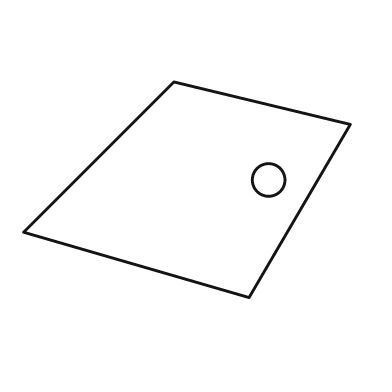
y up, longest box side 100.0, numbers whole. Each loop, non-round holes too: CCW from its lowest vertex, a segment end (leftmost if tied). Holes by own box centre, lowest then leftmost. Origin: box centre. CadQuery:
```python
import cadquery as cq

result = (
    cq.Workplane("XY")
    .moveTo(19.0, -33.0)
    .lineTo(50.0, 20.0)
    .lineTo(-4.0, 33.0)
    .lineTo(-50.0, -13.0)
    .close()
    .moveTo(25.0, 3.0)
    .circle(5.0)
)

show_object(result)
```